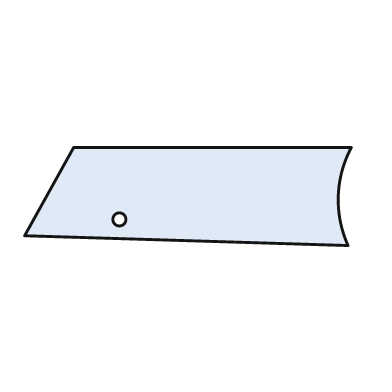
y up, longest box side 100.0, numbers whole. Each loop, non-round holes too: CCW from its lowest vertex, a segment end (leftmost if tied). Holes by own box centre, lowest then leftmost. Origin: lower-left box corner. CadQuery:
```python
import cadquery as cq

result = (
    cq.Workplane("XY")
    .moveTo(99.0, 0.0)
    .threePointArc((96.0, 15.0), (100.0, 30.0))
    .lineTo(15.0, 30.0)
    .lineTo(0.0, 3.0)
    .close()
    .moveTo(29.0, 8.0)
    .circle(2.0)
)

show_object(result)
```